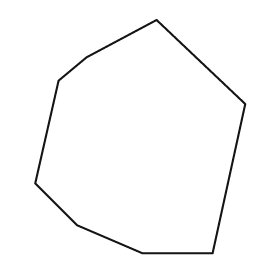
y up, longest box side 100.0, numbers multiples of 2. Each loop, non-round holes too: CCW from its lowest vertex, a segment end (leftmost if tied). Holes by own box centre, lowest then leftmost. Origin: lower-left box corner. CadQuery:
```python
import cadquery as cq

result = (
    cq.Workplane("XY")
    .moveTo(46.0, 0.0)
    .lineTo(76.0, 0.0)
    .lineTo(90.0, 64.0)
    .lineTo(52.0, 100.0)
    .lineTo(22.0, 84.0)
    .lineTo(10.0, 74.0)
    .lineTo(0.0, 30.0)
    .lineTo(18.0, 12.0)
    .close()
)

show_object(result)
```